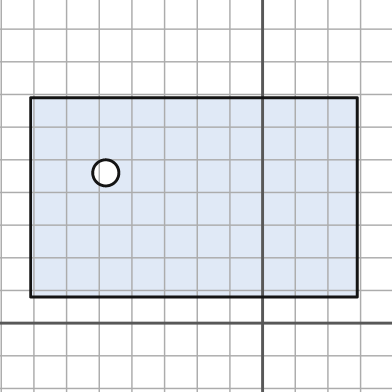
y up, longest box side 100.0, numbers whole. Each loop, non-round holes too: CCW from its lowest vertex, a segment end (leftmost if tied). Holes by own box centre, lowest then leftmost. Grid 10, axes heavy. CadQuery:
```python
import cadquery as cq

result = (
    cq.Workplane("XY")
    .moveTo(-71.0, 8.0)
    .lineTo(29.0, 8.0)
    .lineTo(29.0, 69.0)
    .lineTo(-71.0, 69.0)
    .close()
    .moveTo(-48.0, 46.0)
    .circle(4.0)
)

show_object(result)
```